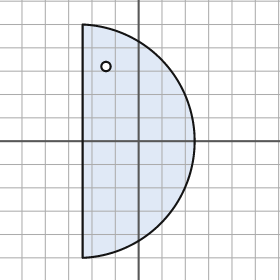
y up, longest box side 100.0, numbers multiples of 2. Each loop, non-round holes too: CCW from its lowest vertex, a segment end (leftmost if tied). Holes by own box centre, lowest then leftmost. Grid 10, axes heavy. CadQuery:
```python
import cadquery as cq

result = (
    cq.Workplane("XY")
    .moveTo(-24.0, -50.0)
    .threePointArc((24.0, 0.0), (-24.0, 50.0))
    .close()
    .moveTo(-14.0, 32.0)
    .circle(2.0)
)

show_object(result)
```